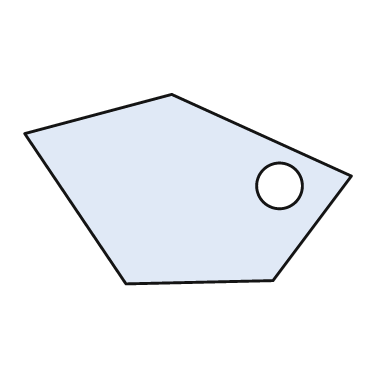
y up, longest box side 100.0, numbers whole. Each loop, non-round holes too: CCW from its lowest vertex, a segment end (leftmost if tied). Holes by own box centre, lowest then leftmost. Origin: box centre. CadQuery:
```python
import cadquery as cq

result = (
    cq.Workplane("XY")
    .moveTo(-19.0, -29.0)
    .lineTo(26.0, -28.0)
    .lineTo(50.0, 4.0)
    .lineTo(-5.0, 29.0)
    .lineTo(-50.0, 17.0)
    .close()
    .moveTo(28.0, 1.0)
    .circle(7.0)
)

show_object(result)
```